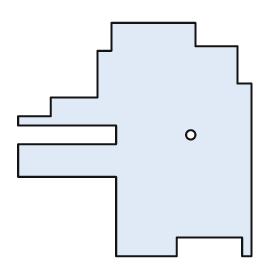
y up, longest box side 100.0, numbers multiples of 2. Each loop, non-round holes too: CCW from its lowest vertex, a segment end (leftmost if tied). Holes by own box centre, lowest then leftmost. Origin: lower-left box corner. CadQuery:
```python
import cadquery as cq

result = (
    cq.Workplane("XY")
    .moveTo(42.0, 0.0)
    .lineTo(68.0, 0.0)
    .lineTo(68.0, 8.0)
    .lineTo(96.0, 8.0)
    .lineTo(96.0, 0.0)
    .lineTo(100.0, 0.0)
    .lineTo(100.0, 74.0)
    .lineTo(94.0, 74.0)
    .lineTo(94.0, 90.0)
    .lineTo(76.0, 90.0)
    .lineTo(76.0, 100.0)
    .lineTo(40.0, 100.0)
    .lineTo(40.0, 88.0)
    .lineTo(34.0, 88.0)
    .lineTo(34.0, 68.0)
    .lineTo(14.0, 68.0)
    .lineTo(14.0, 60.0)
    .lineTo(0.0, 60.0)
    .lineTo(0.0, 56.0)
    .lineTo(42.0, 56.0)
    .lineTo(42.0, 48.0)
    .lineTo(0.0, 48.0)
    .lineTo(0.0, 34.0)
    .lineTo(42.0, 34.0)
    .close()
    .moveTo(74.0, 52.0)
    .circle(2.0)
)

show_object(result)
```